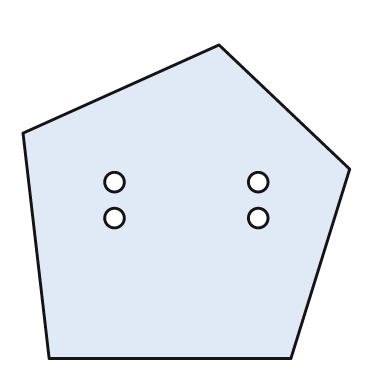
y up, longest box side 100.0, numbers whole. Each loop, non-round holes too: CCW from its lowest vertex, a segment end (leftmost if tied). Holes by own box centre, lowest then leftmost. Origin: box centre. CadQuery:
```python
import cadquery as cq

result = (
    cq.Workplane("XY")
    .moveTo(-42.0, -48.0)
    .lineTo(32.0, -48.0)
    .lineTo(50.0, 10.0)
    .lineTo(10.0, 48.0)
    .lineTo(-50.0, 21.0)
    .close()
    .moveTo(-22.0, -5.0)
    .circle(3.0)
    .moveTo(22.0, -5.0)
    .circle(3.0)
    .moveTo(-22.0, 6.0)
    .circle(3.0)
    .moveTo(22.0, 6.0)
    .circle(3.0)
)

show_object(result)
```